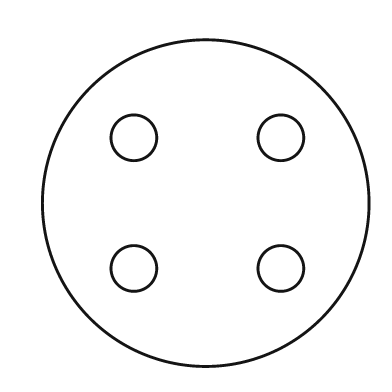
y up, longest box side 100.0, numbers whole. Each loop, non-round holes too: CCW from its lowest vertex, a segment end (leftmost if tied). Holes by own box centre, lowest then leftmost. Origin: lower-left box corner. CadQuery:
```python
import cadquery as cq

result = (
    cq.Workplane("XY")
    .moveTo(50.0, 50.0)
    .circle(50.0)
    .moveTo(28.0, 30.0)
    .circle(7.0)
    .moveTo(73.0, 30.0)
    .circle(7.0)
    .moveTo(28.0, 70.0)
    .circle(7.0)
    .moveTo(73.0, 70.0)
    .circle(7.0)
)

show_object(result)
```